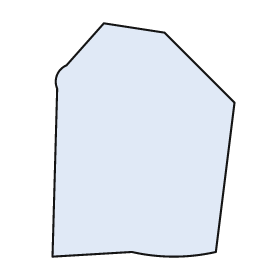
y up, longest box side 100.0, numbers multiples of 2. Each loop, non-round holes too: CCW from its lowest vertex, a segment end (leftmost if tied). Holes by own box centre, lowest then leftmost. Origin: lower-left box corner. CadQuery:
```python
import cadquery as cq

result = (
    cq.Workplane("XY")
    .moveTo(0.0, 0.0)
    .lineTo(34.0, 2.0)
    .threePointArc((52.0, 0.0), (70.0, 2.0))
    .lineTo(78.0, 66.0)
    .lineTo(48.0, 96.0)
    .lineTo(22.0, 100.0)
    .lineTo(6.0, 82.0)
    .threePointArc((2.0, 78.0), (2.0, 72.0))
    .close()
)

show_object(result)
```